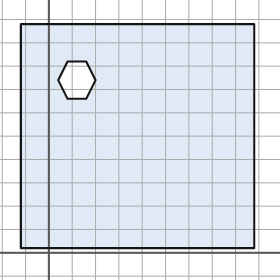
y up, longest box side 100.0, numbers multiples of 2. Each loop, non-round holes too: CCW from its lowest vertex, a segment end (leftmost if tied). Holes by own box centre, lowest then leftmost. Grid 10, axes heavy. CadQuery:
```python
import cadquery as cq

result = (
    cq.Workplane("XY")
    .moveTo(-12.0, 2.0)
    .lineTo(88.0, 2.0)
    .lineTo(88.0, 98.0)
    .lineTo(-12.0, 98.0)
    .close()
    .moveTo(8.0, 66.0)
    .lineTo(16.0, 66.0)
    .lineTo(20.0, 74.0)
    .lineTo(16.0, 82.0)
    .lineTo(8.0, 82.0)
    .lineTo(4.0, 74.0)
    .close()
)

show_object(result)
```